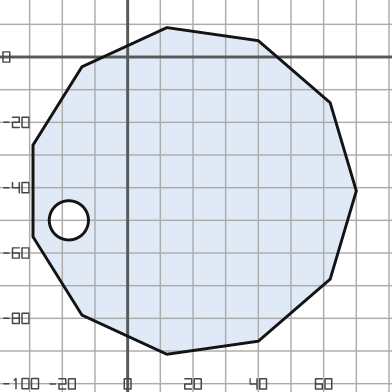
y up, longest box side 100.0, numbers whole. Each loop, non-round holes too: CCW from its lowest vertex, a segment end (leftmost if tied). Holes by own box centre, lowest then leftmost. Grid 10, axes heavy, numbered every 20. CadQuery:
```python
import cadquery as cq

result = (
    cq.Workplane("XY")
    .moveTo(12.0, -91.0)
    .lineTo(40.0, -87.0)
    .lineTo(62.0, -68.0)
    .lineTo(70.0, -41.0)
    .lineTo(62.0, -14.0)
    .lineTo(40.0, 5.0)
    .lineTo(12.0, 9.0)
    .lineTo(-14.0, -3.0)
    .lineTo(-29.0, -27.0)
    .lineTo(-29.0, -55.0)
    .lineTo(-14.0, -79.0)
    .close()
    .moveTo(-18.0, -50.0)
    .circle(6.0)
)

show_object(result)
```